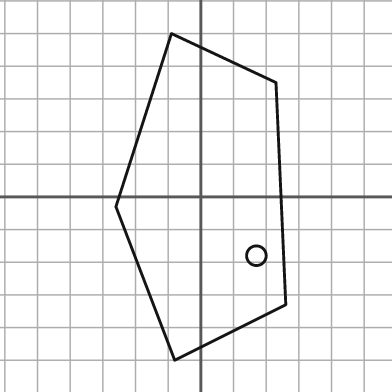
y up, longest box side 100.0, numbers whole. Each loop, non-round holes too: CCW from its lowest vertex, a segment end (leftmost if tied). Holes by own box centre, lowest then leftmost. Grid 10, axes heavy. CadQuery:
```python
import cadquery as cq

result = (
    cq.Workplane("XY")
    .moveTo(-8.0, -50.0)
    .lineTo(26.0, -33.0)
    .lineTo(23.0, 35.0)
    .lineTo(-9.0, 50.0)
    .lineTo(-26.0, -3.0)
    .close()
    .moveTo(17.0, -18.0)
    .circle(3.0)
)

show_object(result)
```